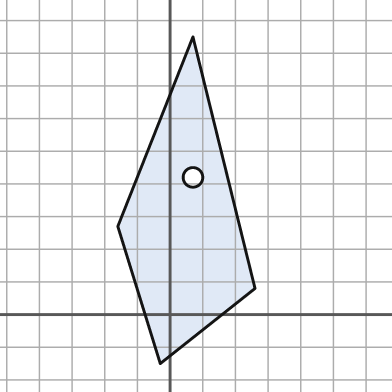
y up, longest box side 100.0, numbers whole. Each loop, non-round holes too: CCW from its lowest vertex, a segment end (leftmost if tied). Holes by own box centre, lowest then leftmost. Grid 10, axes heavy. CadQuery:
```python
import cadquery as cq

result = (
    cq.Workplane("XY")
    .moveTo(-3.0, -15.0)
    .lineTo(26.0, 8.0)
    .lineTo(7.0, 85.0)
    .lineTo(-16.0, 27.0)
    .close()
    .moveTo(7.0, 42.0)
    .circle(3.0)
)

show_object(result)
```